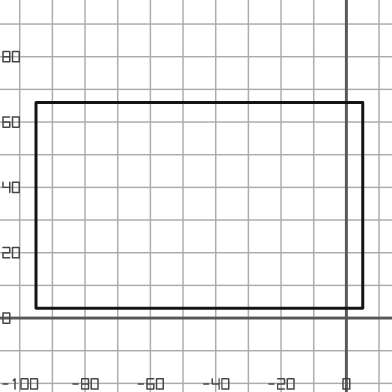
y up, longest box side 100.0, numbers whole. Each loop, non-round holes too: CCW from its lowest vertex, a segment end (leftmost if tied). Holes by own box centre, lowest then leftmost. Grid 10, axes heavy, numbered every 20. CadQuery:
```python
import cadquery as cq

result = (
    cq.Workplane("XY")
    .moveTo(-95.0, 3.0)
    .lineTo(5.0, 3.0)
    .lineTo(5.0, 66.0)
    .lineTo(-95.0, 66.0)
    .close()
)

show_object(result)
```